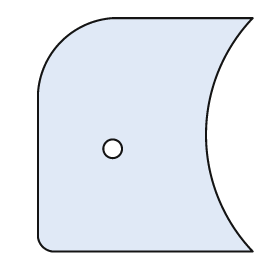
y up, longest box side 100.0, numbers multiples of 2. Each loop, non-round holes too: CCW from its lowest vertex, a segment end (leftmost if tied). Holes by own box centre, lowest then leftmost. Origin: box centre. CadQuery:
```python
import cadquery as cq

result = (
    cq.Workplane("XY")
    .moveTo(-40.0, -50.0)
    .lineTo(46.0, -50.0)
    .threePointArc((26.0, 0.0), (46.0, 50.0))
    .lineTo(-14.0, 50.0)
    .threePointArc((-36.0, 40.0), (-46.0, 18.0))
    .lineTo(-46.0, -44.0)
    .threePointArc((-44.0, -48.0), (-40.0, -50.0))
    .close()
    .moveTo(-14.0, -6.0)
    .circle(4.0)
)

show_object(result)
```